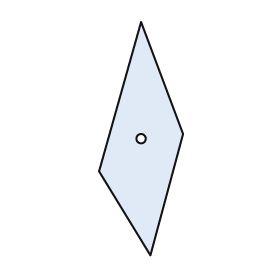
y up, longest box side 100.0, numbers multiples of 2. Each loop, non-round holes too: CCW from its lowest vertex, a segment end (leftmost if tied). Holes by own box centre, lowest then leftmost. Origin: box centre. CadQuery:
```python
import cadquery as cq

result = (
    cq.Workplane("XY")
    .moveTo(4.0, -50.0)
    .lineTo(18.0, 2.0)
    .lineTo(0.0, 50.0)
    .lineTo(-18.0, -14.0)
    .close()
    .moveTo(0.0, 0.0)
    .circle(2.0)
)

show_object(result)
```